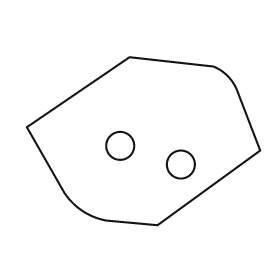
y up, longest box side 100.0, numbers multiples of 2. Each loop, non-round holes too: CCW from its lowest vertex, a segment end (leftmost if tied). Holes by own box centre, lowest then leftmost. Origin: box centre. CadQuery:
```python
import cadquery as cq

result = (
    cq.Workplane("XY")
    .moveTo(6.0, -36.0)
    .lineTo(50.0, -4.0)
    .lineTo(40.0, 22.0)
    .threePointArc((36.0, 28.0), (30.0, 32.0))
    .lineTo(-6.0, 36.0)
    .lineTo(-50.0, 6.0)
    .lineTo(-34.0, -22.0)
    .threePointArc((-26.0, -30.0), (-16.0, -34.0))
    .close()
    .moveTo(16.0, -10.0)
    .circle(6.0)
    .moveTo(-10.0, -2.0)
    .circle(6.0)
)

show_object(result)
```